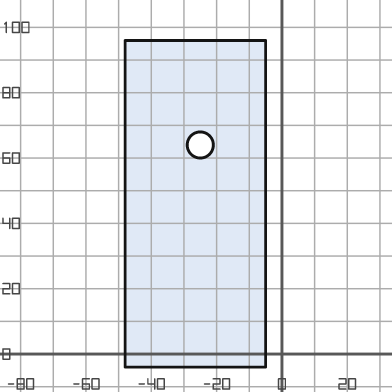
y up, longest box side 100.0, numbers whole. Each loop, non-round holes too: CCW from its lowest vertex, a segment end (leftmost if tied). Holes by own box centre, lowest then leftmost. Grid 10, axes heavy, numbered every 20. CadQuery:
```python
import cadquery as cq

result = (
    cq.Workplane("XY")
    .moveTo(-48.0, -4.0)
    .lineTo(-5.0, -4.0)
    .lineTo(-5.0, 96.0)
    .lineTo(-48.0, 96.0)
    .close()
    .moveTo(-25.0, 64.0)
    .circle(4.0)
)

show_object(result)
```